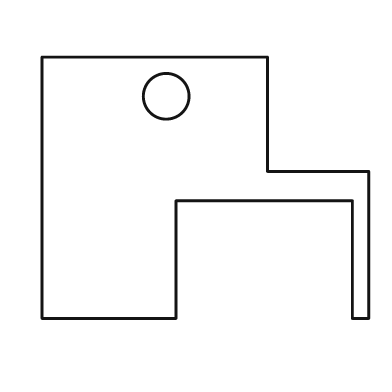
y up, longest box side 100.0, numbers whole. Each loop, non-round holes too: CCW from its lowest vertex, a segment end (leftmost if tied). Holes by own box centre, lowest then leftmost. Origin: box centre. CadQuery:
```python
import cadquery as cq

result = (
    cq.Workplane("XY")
    .moveTo(-50.0, -40.0)
    .lineTo(-9.0, -40.0)
    .lineTo(-9.0, -4.0)
    .lineTo(45.0, -4.0)
    .lineTo(45.0, -40.0)
    .lineTo(50.0, -40.0)
    .lineTo(50.0, 5.0)
    .lineTo(19.0, 5.0)
    .lineTo(19.0, 40.0)
    .lineTo(-50.0, 40.0)
    .close()
    .moveTo(-12.0, 28.0)
    .circle(7.0)
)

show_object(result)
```